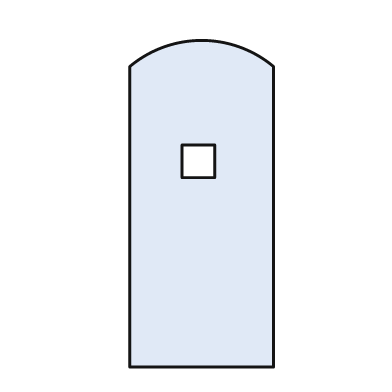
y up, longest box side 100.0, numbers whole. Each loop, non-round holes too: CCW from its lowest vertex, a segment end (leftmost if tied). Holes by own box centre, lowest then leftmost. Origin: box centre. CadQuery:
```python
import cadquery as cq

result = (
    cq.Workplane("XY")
    .moveTo(-22.0, -50.0)
    .lineTo(22.0, -50.0)
    .lineTo(22.0, 42.0)
    .threePointArc((0.0, 50.0), (-22.0, 42.0))
    .close()
    .moveTo(-6.0, 8.0)
    .lineTo(4.0, 8.0)
    .lineTo(4.0, 18.0)
    .lineTo(-6.0, 18.0)
    .close()
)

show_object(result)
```